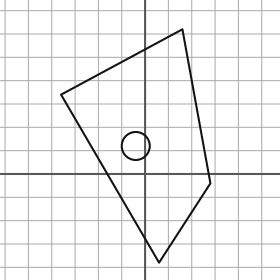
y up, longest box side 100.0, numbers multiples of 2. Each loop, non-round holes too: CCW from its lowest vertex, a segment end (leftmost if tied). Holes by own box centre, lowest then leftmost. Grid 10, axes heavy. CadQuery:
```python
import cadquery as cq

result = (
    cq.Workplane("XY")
    .moveTo(6.0, -38.0)
    .lineTo(28.0, -4.0)
    .lineTo(16.0, 62.0)
    .lineTo(-36.0, 34.0)
    .close()
    .moveTo(-4.0, 12.0)
    .circle(6.0)
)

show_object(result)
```